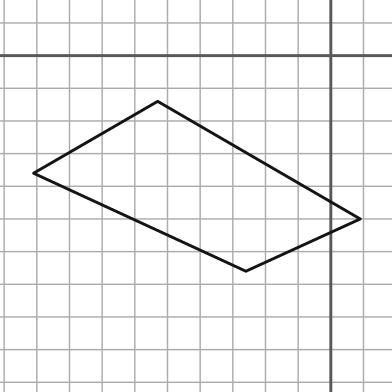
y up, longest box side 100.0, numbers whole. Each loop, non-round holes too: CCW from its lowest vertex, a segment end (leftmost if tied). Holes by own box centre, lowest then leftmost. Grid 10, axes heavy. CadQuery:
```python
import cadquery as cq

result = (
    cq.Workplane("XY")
    .moveTo(-26.0, -66.0)
    .lineTo(9.0, -50.0)
    .lineTo(-53.0, -14.0)
    .lineTo(-91.0, -36.0)
    .close()
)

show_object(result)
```